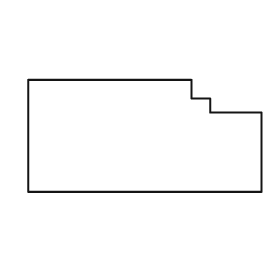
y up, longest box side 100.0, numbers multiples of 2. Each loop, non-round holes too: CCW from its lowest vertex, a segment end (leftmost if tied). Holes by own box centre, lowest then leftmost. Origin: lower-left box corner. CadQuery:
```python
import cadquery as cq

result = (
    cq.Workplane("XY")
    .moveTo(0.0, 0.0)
    .lineTo(100.0, 0.0)
    .lineTo(100.0, 34.0)
    .lineTo(78.0, 34.0)
    .lineTo(78.0, 40.0)
    .lineTo(70.0, 40.0)
    .lineTo(70.0, 48.0)
    .lineTo(0.0, 48.0)
    .close()
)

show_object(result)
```